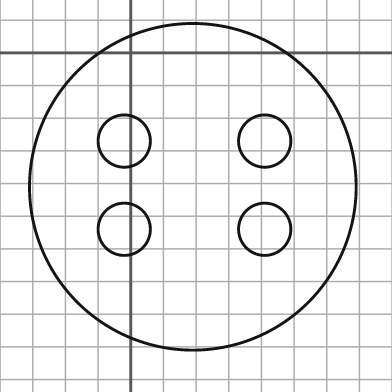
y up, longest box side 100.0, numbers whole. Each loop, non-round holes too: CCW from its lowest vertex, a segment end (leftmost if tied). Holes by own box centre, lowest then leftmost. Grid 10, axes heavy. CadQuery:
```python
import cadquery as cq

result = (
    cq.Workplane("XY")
    .moveTo(19.0, -41.0)
    .circle(50.0)
    .moveTo(-2.0, -54.0)
    .circle(8.0)
    .moveTo(41.0, -54.0)
    .circle(8.0)
    .moveTo(-2.0, -27.0)
    .circle(8.0)
    .moveTo(41.0, -27.0)
    .circle(8.0)
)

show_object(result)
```